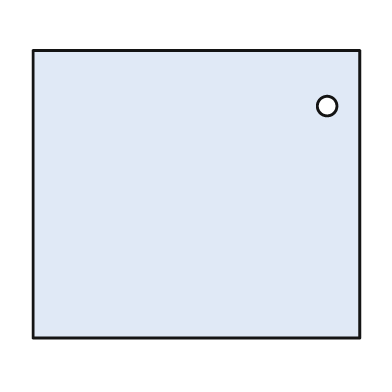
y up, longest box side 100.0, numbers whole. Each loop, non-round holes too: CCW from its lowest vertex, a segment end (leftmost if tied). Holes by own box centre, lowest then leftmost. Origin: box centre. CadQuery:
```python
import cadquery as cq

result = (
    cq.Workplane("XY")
    .moveTo(-50.0, -44.0)
    .lineTo(50.0, -44.0)
    .lineTo(50.0, 44.0)
    .lineTo(-50.0, 44.0)
    .close()
    .moveTo(40.0, 27.0)
    .circle(3.0)
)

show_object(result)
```